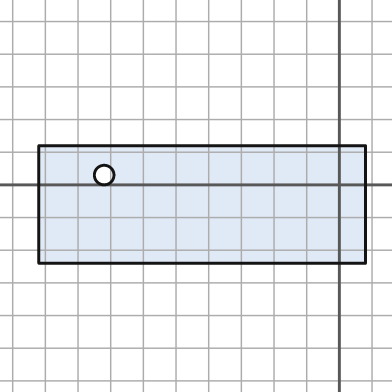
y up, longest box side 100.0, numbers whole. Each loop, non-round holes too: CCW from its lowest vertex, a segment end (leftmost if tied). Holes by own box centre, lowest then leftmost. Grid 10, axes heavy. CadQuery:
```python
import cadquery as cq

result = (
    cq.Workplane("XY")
    .moveTo(-92.0, -24.0)
    .lineTo(8.0, -24.0)
    .lineTo(8.0, 12.0)
    .lineTo(-92.0, 12.0)
    .close()
    .moveTo(-72.0, 3.0)
    .circle(3.0)
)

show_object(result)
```